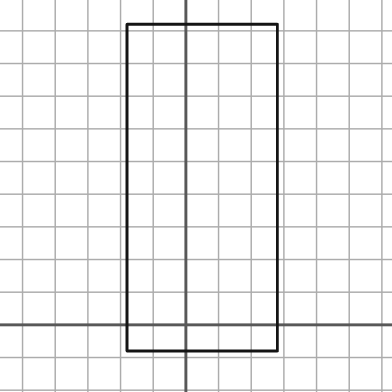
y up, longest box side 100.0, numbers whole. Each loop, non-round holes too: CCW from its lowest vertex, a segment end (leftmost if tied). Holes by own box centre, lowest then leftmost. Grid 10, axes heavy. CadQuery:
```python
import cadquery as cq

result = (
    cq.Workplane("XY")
    .moveTo(-18.0, -8.0)
    .lineTo(28.0, -8.0)
    .lineTo(28.0, 92.0)
    .lineTo(-18.0, 92.0)
    .close()
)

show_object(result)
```